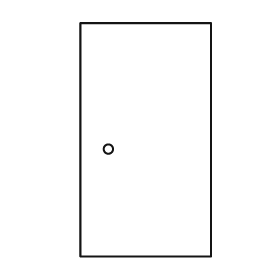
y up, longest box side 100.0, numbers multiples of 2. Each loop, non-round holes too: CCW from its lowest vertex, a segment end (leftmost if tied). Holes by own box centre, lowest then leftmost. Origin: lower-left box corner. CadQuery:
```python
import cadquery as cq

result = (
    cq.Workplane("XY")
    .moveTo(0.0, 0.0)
    .lineTo(56.0, 0.0)
    .lineTo(56.0, 100.0)
    .lineTo(0.0, 100.0)
    .close()
    .moveTo(12.0, 46.0)
    .circle(2.0)
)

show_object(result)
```